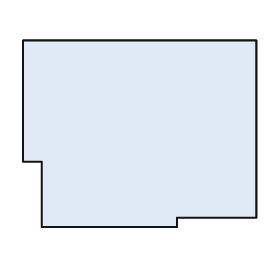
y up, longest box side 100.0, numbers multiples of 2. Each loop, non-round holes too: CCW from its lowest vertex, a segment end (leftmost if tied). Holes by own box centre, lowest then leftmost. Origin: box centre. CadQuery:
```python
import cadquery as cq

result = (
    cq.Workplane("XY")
    .moveTo(-42.0, -40.0)
    .lineTo(16.0, -40.0)
    .lineTo(16.0, -36.0)
    .lineTo(50.0, -36.0)
    .lineTo(50.0, 40.0)
    .lineTo(-50.0, 40.0)
    .lineTo(-50.0, -12.0)
    .lineTo(-42.0, -12.0)
    .close()
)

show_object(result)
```